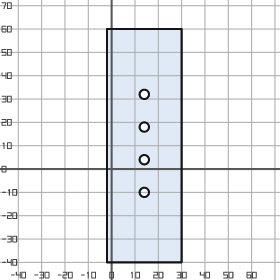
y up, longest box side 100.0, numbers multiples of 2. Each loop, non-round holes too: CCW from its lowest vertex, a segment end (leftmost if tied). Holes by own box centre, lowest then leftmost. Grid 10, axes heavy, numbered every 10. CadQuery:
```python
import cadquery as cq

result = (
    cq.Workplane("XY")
    .moveTo(-2.0, -40.0)
    .lineTo(30.0, -40.0)
    .lineTo(30.0, 60.0)
    .lineTo(-2.0, 60.0)
    .close()
    .moveTo(14.0, -10.0)
    .circle(2.0)
    .moveTo(14.0, 4.0)
    .circle(2.0)
    .moveTo(14.0, 18.0)
    .circle(2.0)
    .moveTo(14.0, 32.0)
    .circle(2.0)
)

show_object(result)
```